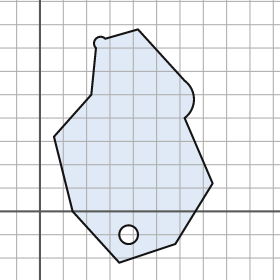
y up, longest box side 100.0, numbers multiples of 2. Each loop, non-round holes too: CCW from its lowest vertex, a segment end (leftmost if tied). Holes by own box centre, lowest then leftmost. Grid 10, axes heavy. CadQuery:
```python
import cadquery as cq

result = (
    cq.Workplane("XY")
    .moveTo(34.0, -22.0)
    .lineTo(58.0, -14.0)
    .lineTo(74.0, 12.0)
    .lineTo(62.0, 40.0)
    .threePointArc((66.0, 48.0), (62.0, 56.0))
    .lineTo(42.0, 78.0)
    .lineTo(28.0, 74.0)
    .threePointArc((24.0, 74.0), (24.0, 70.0))
    .lineTo(22.0, 50.0)
    .lineTo(6.0, 32.0)
    .lineTo(14.0, 0.0)
    .close()
    .moveTo(38.0, -10.0)
    .circle(4.0)
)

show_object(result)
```